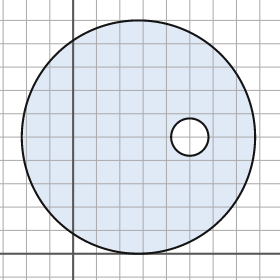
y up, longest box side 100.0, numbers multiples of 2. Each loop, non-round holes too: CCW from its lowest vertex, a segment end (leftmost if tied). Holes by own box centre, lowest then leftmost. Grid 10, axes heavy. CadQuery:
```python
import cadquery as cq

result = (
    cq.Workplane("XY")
    .moveTo(28.0, 50.0)
    .circle(50.0)
    .moveTo(50.0, 50.0)
    .circle(8.0)
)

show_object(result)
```